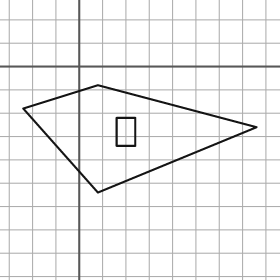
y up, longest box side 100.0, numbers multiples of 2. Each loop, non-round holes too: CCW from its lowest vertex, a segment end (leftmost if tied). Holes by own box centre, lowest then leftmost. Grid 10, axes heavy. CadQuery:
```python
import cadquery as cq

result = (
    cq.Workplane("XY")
    .moveTo(8.0, -54.0)
    .lineTo(76.0, -26.0)
    .lineTo(8.0, -8.0)
    .lineTo(-24.0, -18.0)
    .close()
    .moveTo(16.0, -34.0)
    .lineTo(24.0, -34.0)
    .lineTo(24.0, -22.0)
    .lineTo(16.0, -22.0)
    .close()
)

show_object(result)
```